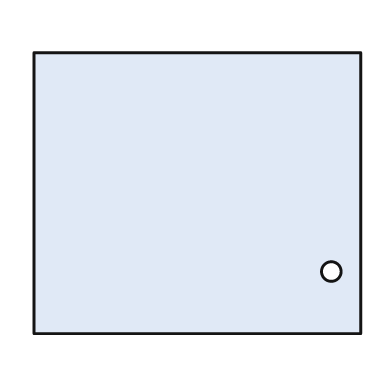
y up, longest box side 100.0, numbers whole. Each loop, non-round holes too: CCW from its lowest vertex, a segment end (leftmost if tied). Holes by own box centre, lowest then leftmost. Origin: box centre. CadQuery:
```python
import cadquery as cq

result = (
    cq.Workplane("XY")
    .moveTo(-50.0, -43.0)
    .lineTo(50.0, -43.0)
    .lineTo(50.0, 43.0)
    .lineTo(-50.0, 43.0)
    .close()
    .moveTo(41.0, -24.0)
    .circle(3.0)
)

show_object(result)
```